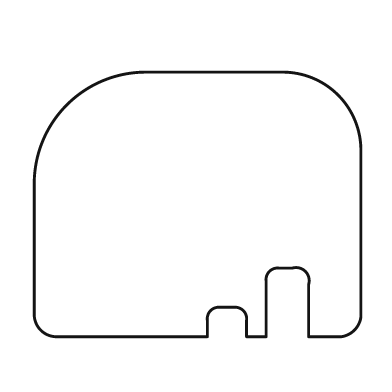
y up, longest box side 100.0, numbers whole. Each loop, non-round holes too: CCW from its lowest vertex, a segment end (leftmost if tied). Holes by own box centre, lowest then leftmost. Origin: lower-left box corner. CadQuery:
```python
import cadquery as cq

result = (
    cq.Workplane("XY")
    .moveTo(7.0, 0.0)
    .lineTo(53.0, 0.0)
    .lineTo(53.0, 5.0)
    .threePointArc((54.0, 8.0), (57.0, 9.0))
    .lineTo(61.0, 9.0)
    .threePointArc((64.0, 8.0), (65.0, 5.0))
    .lineTo(65.0, 0.0)
    .lineTo(71.0, 0.0)
    .lineTo(71.0, 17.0)
    .threePointArc((72.0, 20.0), (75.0, 21.0))
    .lineTo(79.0, 21.0)
    .threePointArc((83.0, 20.0), (84.0, 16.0))
    .lineTo(84.0, 0.0)
    .lineTo(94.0, 0.0)
    .threePointArc((98.0, 2.0), (100.0, 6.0))
    .lineTo(100.0, 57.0)
    .threePointArc((93.0, 74.0), (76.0, 81.0))
    .lineTo(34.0, 81.0)
    .threePointArc((10.0, 71.0), (0.0, 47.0))
    .lineTo(0.0, 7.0)
    .threePointArc((2.0, 2.0), (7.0, 0.0))
    .close()
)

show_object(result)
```